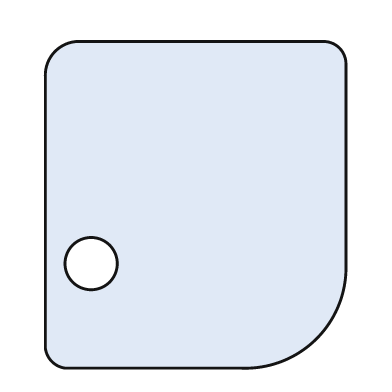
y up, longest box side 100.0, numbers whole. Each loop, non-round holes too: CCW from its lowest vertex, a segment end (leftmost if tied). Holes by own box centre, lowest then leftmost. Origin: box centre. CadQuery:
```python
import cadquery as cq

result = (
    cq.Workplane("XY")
    .moveTo(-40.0, -50.0)
    .lineTo(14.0, -50.0)
    .threePointArc((37.0, -41.0), (46.0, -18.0))
    .lineTo(46.0, 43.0)
    .threePointArc((44.0, 48.0), (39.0, 50.0))
    .lineTo(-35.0, 50.0)
    .threePointArc((-43.0, 47.0), (-46.0, 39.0))
    .lineTo(-46.0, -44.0)
    .threePointArc((-44.0, -48.0), (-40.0, -50.0))
    .close()
    .moveTo(-32.0, -18.0)
    .circle(8.0)
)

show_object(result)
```